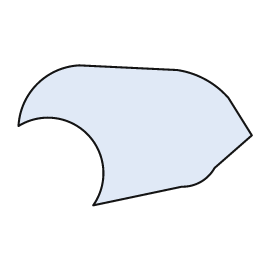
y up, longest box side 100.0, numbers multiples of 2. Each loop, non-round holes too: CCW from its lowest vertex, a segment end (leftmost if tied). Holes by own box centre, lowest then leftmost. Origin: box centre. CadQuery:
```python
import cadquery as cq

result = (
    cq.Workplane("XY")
    .moveTo(-18.0, -30.0)
    .lineTo(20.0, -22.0)
    .threePointArc((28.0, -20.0), (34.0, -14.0))
    .lineTo(50.0, 0.0)
    .lineTo(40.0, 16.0)
    .threePointArc((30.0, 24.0), (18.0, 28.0))
    .lineTo(-24.0, 30.0)
    .threePointArc((-42.0, 22.0), (-50.0, 4.0))
    .threePointArc((-20.0, 0.0), (-18.0, -30.0))
    .close()
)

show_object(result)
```